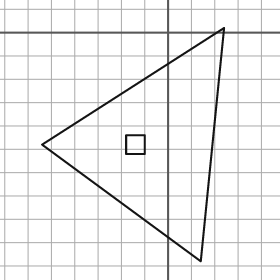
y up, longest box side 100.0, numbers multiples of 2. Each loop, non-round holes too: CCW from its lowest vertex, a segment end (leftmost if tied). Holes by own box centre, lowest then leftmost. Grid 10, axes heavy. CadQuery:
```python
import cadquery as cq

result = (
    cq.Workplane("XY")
    .moveTo(14.0, -98.0)
    .lineTo(24.0, 2.0)
    .lineTo(-54.0, -48.0)
    .close()
    .moveTo(-18.0, -52.0)
    .lineTo(-10.0, -52.0)
    .lineTo(-10.0, -44.0)
    .lineTo(-18.0, -44.0)
    .close()
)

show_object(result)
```